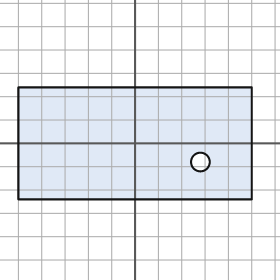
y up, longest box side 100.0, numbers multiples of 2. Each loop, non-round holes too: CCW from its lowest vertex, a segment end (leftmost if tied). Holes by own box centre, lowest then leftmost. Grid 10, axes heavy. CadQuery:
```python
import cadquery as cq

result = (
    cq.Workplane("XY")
    .moveTo(-50.0, -24.0)
    .lineTo(50.0, -24.0)
    .lineTo(50.0, 24.0)
    .lineTo(-50.0, 24.0)
    .close()
    .moveTo(28.0, -8.0)
    .circle(4.0)
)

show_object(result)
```